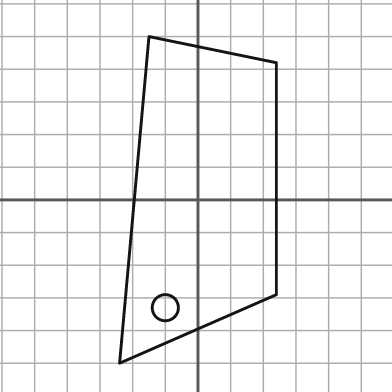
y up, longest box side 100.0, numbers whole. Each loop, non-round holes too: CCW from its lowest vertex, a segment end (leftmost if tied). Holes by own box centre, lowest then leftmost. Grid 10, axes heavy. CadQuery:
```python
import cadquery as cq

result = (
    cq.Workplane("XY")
    .moveTo(-24.0, -50.0)
    .lineTo(24.0, -29.0)
    .lineTo(24.0, 42.0)
    .lineTo(-15.0, 50.0)
    .close()
    .moveTo(-10.0, -33.0)
    .circle(4.0)
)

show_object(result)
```